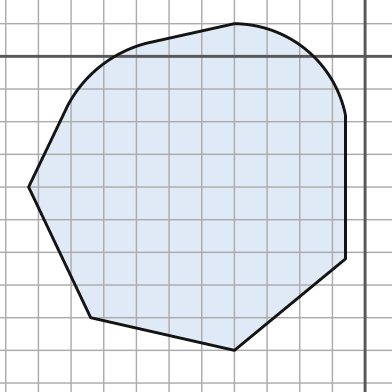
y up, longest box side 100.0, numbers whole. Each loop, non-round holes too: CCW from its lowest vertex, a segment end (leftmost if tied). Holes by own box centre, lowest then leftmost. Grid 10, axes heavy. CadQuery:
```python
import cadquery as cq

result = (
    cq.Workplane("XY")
    .moveTo(-40.0, -90.0)
    .lineTo(-6.0, -62.0)
    .lineTo(-6.0, -18.0)
    .threePointArc((-18.0, 2.0), (-40.0, 10.0))
    .lineTo(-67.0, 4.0)
    .threePointArc((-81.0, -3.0), (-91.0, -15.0))
    .lineTo(-103.0, -40.0)
    .lineTo(-84.0, -80.0)
    .close()
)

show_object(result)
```